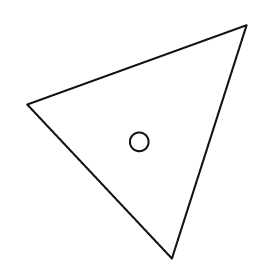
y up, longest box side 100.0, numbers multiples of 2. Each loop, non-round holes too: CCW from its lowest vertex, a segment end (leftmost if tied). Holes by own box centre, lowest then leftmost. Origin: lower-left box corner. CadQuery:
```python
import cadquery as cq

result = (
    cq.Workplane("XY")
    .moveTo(62.0, 0.0)
    .lineTo(94.0, 100.0)
    .lineTo(0.0, 66.0)
    .close()
    .moveTo(48.0, 50.0)
    .circle(4.0)
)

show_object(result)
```